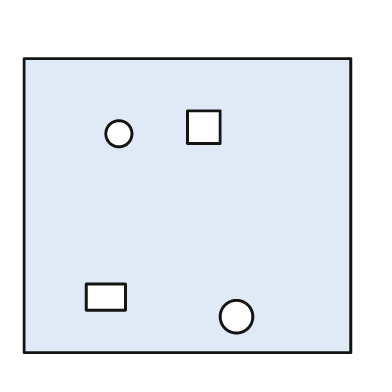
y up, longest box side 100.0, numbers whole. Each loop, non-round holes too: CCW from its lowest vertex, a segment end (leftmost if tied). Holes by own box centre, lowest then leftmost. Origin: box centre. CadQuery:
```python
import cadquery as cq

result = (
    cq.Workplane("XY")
    .moveTo(-50.0, -45.0)
    .lineTo(50.0, -45.0)
    .lineTo(50.0, 45.0)
    .lineTo(-50.0, 45.0)
    .close()
    .moveTo(15.0, -34.0)
    .circle(5.0)
    .moveTo(-31.0, -32.0)
    .lineTo(-19.0, -32.0)
    .lineTo(-19.0, -24.0)
    .lineTo(-31.0, -24.0)
    .close()
    .moveTo(-21.0, 22.0)
    .circle(4.0)
    .moveTo(0.0, 19.0)
    .lineTo(10.0, 19.0)
    .lineTo(10.0, 29.0)
    .lineTo(0.0, 29.0)
    .close()
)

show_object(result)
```